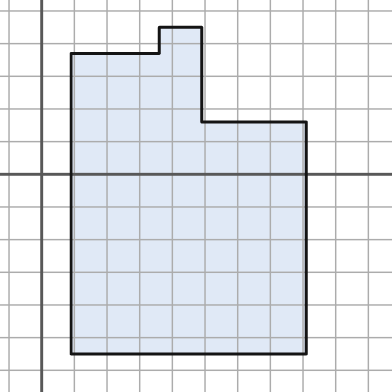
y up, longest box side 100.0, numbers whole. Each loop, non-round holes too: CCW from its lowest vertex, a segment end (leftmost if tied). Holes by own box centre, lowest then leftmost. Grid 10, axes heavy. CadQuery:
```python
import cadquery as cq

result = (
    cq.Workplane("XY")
    .moveTo(9.0, -55.0)
    .lineTo(81.0, -55.0)
    .lineTo(81.0, 16.0)
    .lineTo(49.0, 16.0)
    .lineTo(49.0, 45.0)
    .lineTo(36.0, 45.0)
    .lineTo(36.0, 37.0)
    .lineTo(9.0, 37.0)
    .close()
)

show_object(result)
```